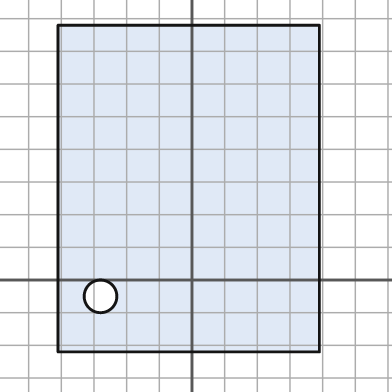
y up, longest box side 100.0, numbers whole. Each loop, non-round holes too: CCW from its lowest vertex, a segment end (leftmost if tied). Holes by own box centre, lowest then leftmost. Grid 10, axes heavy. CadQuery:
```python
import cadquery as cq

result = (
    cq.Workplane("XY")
    .moveTo(-41.0, -22.0)
    .lineTo(39.0, -22.0)
    .lineTo(39.0, 78.0)
    .lineTo(-41.0, 78.0)
    .close()
    .moveTo(-28.0, -5.0)
    .circle(5.0)
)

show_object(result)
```